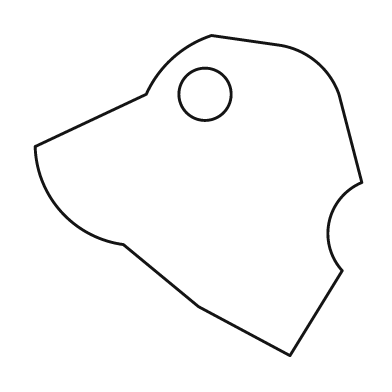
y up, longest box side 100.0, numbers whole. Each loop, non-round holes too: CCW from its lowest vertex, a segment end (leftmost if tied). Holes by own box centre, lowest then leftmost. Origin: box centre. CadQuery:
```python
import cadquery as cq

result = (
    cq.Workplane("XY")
    .moveTo(28.0, -49.0)
    .lineTo(44.0, -23.0)
    .threePointArc((40.0, -8.0), (50.0, 4.0))
    .lineTo(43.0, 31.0)
    .threePointArc((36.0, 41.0), (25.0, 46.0))
    .lineTo(4.0, 49.0)
    .threePointArc((-8.0, 42.0), (-16.0, 31.0))
    .lineTo(-50.0, 15.0)
    .threePointArc((-42.0, -5.0), (-23.0, -15.0))
    .lineTo(0.0, -34.0)
    .close()
    .moveTo(2.0, 31.0)
    .circle(8.0)
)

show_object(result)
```